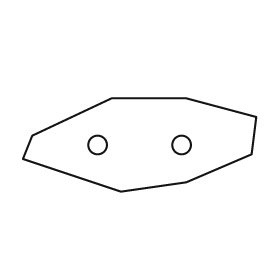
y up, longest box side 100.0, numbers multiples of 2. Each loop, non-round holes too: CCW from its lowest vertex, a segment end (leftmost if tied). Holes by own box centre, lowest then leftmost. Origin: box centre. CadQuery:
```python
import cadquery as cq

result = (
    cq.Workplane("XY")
    .moveTo(-8.0, -20.0)
    .lineTo(20.0, -16.0)
    .lineTo(48.0, -4.0)
    .lineTo(50.0, 12.0)
    .lineTo(20.0, 20.0)
    .lineTo(-12.0, 20.0)
    .lineTo(-46.0, 4.0)
    .lineTo(-50.0, -6.0)
    .close()
    .moveTo(-18.0, 0.0)
    .circle(4.0)
    .moveTo(18.0, 0.0)
    .circle(4.0)
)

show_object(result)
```